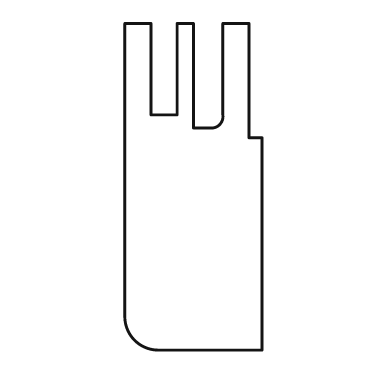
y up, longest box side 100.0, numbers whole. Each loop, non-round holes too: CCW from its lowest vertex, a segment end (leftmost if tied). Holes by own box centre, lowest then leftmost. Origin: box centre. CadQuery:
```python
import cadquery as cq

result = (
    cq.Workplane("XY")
    .moveTo(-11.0, -50.0)
    .lineTo(21.0, -50.0)
    .lineTo(21.0, 15.0)
    .lineTo(17.0, 15.0)
    .lineTo(17.0, 50.0)
    .lineTo(9.0, 50.0)
    .lineTo(9.0, 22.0)
    .threePointArc((8.0, 19.0), (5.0, 18.0))
    .lineTo(0.0, 18.0)
    .lineTo(0.0, 50.0)
    .lineTo(-5.0, 50.0)
    .lineTo(-5.0, 22.0)
    .lineTo(-13.0, 22.0)
    .lineTo(-13.0, 50.0)
    .lineTo(-21.0, 50.0)
    .lineTo(-21.0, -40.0)
    .threePointArc((-18.0, -47.0), (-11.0, -50.0))
    .close()
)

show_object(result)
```